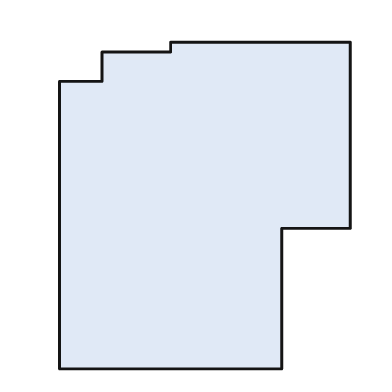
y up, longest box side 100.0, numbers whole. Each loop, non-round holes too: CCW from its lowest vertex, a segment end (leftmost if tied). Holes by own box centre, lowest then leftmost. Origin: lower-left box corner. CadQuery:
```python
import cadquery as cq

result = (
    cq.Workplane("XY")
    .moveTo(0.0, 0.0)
    .lineTo(68.0, 0.0)
    .lineTo(68.0, 43.0)
    .lineTo(89.0, 43.0)
    .lineTo(89.0, 100.0)
    .lineTo(34.0, 100.0)
    .lineTo(34.0, 97.0)
    .lineTo(13.0, 97.0)
    .lineTo(13.0, 88.0)
    .lineTo(0.0, 88.0)
    .close()
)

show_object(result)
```